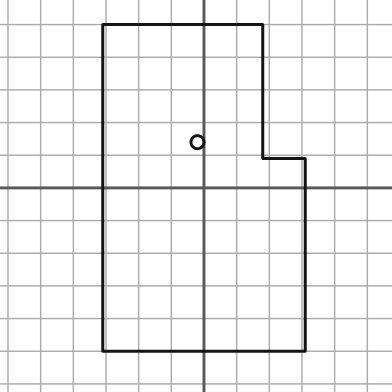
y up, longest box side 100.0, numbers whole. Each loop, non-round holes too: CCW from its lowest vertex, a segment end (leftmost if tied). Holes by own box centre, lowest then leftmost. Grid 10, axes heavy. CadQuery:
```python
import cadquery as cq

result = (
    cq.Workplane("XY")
    .moveTo(-31.0, -50.0)
    .lineTo(31.0, -50.0)
    .lineTo(31.0, 9.0)
    .lineTo(18.0, 9.0)
    .lineTo(18.0, 50.0)
    .lineTo(-31.0, 50.0)
    .close()
    .moveTo(-2.0, 14.0)
    .circle(2.0)
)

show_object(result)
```